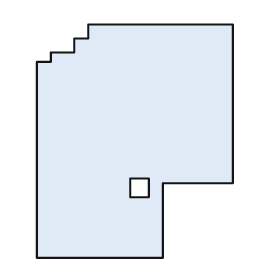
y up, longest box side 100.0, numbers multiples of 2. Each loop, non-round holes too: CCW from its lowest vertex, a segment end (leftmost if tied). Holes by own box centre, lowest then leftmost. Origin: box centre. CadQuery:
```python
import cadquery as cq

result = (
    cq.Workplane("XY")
    .moveTo(-42.0, -50.0)
    .lineTo(12.0, -50.0)
    .lineTo(12.0, -18.0)
    .lineTo(42.0, -18.0)
    .lineTo(42.0, 50.0)
    .lineTo(-20.0, 50.0)
    .lineTo(-20.0, 44.0)
    .lineTo(-26.0, 44.0)
    .lineTo(-26.0, 38.0)
    .lineTo(-36.0, 38.0)
    .lineTo(-36.0, 34.0)
    .lineTo(-42.0, 34.0)
    .close()
    .moveTo(-2.0, -24.0)
    .lineTo(6.0, -24.0)
    .lineTo(6.0, -16.0)
    .lineTo(-2.0, -16.0)
    .close()
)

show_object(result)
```